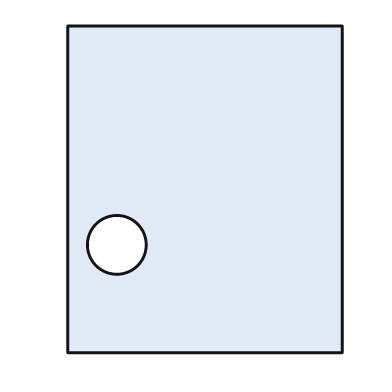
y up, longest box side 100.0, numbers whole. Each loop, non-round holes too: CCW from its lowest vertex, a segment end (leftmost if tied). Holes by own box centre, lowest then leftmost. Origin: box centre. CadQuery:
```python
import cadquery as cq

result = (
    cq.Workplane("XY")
    .moveTo(-42.0, -50.0)
    .lineTo(42.0, -50.0)
    .lineTo(42.0, 50.0)
    .lineTo(-42.0, 50.0)
    .close()
    .moveTo(-27.0, -17.0)
    .circle(9.0)
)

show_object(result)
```